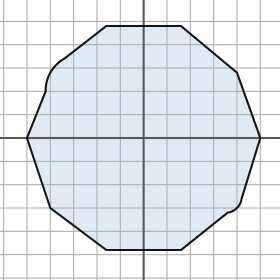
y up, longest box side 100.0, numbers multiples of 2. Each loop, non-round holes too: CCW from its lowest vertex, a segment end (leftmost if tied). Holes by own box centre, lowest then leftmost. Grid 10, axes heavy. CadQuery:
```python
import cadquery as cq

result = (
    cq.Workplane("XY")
    .moveTo(-16.0, -48.0)
    .lineTo(16.0, -48.0)
    .lineTo(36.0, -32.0)
    .threePointArc((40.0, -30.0), (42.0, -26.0))
    .lineTo(50.0, 0.0)
    .lineTo(40.0, 28.0)
    .lineTo(16.0, 48.0)
    .lineTo(-16.0, 48.0)
    .lineTo(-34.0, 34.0)
    .threePointArc((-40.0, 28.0), (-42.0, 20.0))
    .lineTo(-50.0, 0.0)
    .lineTo(-40.0, -30.0)
    .close()
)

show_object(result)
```